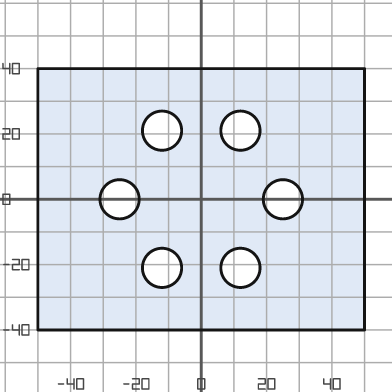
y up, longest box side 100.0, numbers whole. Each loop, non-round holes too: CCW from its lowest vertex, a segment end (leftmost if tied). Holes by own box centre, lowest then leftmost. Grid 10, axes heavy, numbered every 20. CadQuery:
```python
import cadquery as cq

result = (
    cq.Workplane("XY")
    .moveTo(-50.0, -40.0)
    .lineTo(50.0, -40.0)
    .lineTo(50.0, 40.0)
    .lineTo(-50.0, 40.0)
    .close()
    .moveTo(-12.0, -21.0)
    .circle(6.0)
    .moveTo(12.0, -21.0)
    .circle(6.0)
    .moveTo(-25.0, 0.0)
    .circle(6.0)
    .moveTo(25.0, 0.0)
    .circle(6.0)
    .moveTo(-12.0, 21.0)
    .circle(6.0)
    .moveTo(12.0, 21.0)
    .circle(6.0)
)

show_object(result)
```